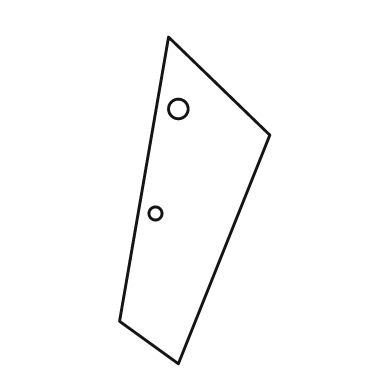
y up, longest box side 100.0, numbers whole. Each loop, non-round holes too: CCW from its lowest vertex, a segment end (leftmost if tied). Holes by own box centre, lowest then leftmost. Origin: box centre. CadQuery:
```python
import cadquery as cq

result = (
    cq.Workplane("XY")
    .moveTo(-5.0, -50.0)
    .lineTo(23.0, 20.0)
    .lineTo(-8.0, 50.0)
    .lineTo(-23.0, -37.0)
    .close()
    .moveTo(-12.0, -4.0)
    .circle(2.0)
    .moveTo(-5.0, 28.0)
    .circle(3.0)
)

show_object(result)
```